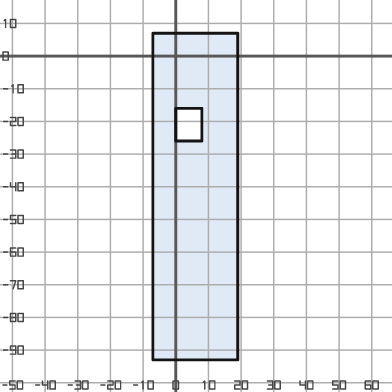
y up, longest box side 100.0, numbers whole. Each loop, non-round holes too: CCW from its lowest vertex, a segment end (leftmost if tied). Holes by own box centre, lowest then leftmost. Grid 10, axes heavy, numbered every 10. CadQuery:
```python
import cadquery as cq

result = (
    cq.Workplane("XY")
    .moveTo(-7.0, -93.0)
    .lineTo(19.0, -93.0)
    .lineTo(19.0, 7.0)
    .lineTo(-7.0, 7.0)
    .close()
    .moveTo(0.0, -26.0)
    .lineTo(8.0, -26.0)
    .lineTo(8.0, -16.0)
    .lineTo(0.0, -16.0)
    .close()
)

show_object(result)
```